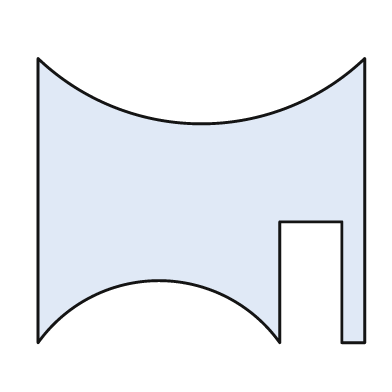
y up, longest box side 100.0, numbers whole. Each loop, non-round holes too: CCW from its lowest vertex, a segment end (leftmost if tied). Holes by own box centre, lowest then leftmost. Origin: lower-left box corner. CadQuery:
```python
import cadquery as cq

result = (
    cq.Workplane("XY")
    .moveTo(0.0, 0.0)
    .threePointArc((37.0, 19.0), (74.0, 0.0))
    .lineTo(74.0, 37.0)
    .lineTo(93.0, 37.0)
    .lineTo(93.0, 0.0)
    .lineTo(100.0, 0.0)
    .lineTo(100.0, 87.0)
    .threePointArc((50.0, 67.0), (0.0, 87.0))
    .close()
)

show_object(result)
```